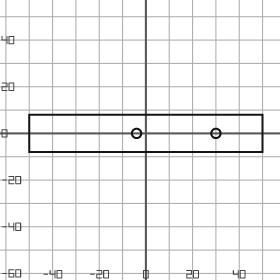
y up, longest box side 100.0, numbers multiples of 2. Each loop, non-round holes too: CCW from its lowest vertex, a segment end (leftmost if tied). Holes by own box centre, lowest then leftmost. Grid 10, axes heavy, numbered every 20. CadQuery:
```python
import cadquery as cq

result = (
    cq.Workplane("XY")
    .moveTo(-50.0, -8.0)
    .lineTo(50.0, -8.0)
    .lineTo(50.0, 8.0)
    .lineTo(-50.0, 8.0)
    .close()
    .moveTo(-4.0, 0.0)
    .circle(2.0)
    .moveTo(30.0, 0.0)
    .circle(2.0)
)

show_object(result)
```